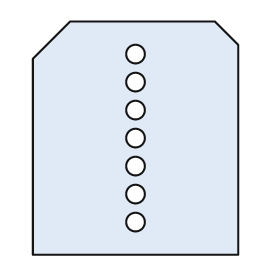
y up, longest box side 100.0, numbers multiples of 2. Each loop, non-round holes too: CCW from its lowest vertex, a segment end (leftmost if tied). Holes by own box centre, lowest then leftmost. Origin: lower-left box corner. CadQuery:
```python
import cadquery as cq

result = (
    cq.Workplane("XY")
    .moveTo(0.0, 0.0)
    .lineTo(88.0, 0.0)
    .lineTo(88.0, 90.0)
    .lineTo(78.0, 100.0)
    .lineTo(16.0, 100.0)
    .lineTo(0.0, 84.0)
    .close()
    .moveTo(44.0, 14.0)
    .circle(4.0)
    .moveTo(44.0, 26.0)
    .circle(4.0)
    .moveTo(44.0, 38.0)
    .circle(4.0)
    .moveTo(44.0, 50.0)
    .circle(4.0)
    .moveTo(44.0, 62.0)
    .circle(4.0)
    .moveTo(44.0, 74.0)
    .circle(4.0)
    .moveTo(44.0, 86.0)
    .circle(4.0)
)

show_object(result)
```